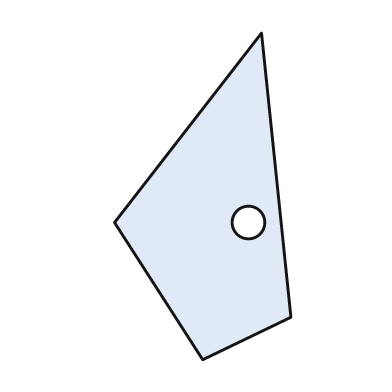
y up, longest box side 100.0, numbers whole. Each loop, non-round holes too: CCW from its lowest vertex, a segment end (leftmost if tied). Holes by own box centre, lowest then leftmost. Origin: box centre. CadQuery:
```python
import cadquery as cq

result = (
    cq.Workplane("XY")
    .moveTo(0.0, -50.0)
    .lineTo(27.0, -37.0)
    .lineTo(18.0, 50.0)
    .lineTo(-27.0, -8.0)
    .close()
    .moveTo(14.0, -8.0)
    .circle(5.0)
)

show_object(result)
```